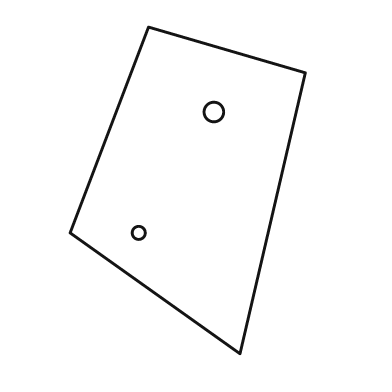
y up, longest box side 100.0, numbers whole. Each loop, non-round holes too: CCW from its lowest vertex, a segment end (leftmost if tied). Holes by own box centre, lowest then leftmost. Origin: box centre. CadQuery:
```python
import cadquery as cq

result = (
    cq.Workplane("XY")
    .moveTo(16.0, -50.0)
    .lineTo(36.0, 36.0)
    .lineTo(-12.0, 50.0)
    .lineTo(-36.0, -13.0)
    .close()
    .moveTo(-15.0, -13.0)
    .circle(2.0)
    .moveTo(8.0, 24.0)
    .circle(3.0)
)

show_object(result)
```